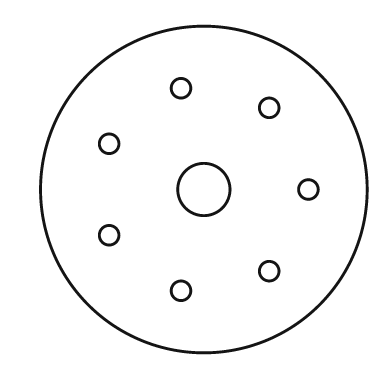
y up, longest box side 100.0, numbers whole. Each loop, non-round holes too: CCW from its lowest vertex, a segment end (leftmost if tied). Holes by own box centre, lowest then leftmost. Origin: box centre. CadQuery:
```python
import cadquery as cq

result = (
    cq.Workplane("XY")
    .moveTo(0.0, 0.0)
    .circle(50.0)
    .moveTo(-7.0, -31.0)
    .circle(3.0)
    .moveTo(20.0, -25.0)
    .circle(3.0)
    .moveTo(-29.0, -14.0)
    .circle(3.0)
    .moveTo(0.0, 0.0)
    .circle(8.0)
    .moveTo(32.0, 0.0)
    .circle(3.0)
    .moveTo(-29.0, 14.0)
    .circle(3.0)
    .moveTo(20.0, 25.0)
    .circle(3.0)
    .moveTo(-7.0, 31.0)
    .circle(3.0)
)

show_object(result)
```